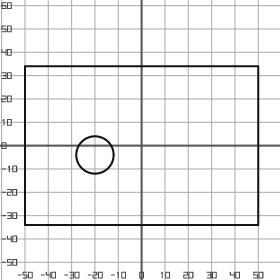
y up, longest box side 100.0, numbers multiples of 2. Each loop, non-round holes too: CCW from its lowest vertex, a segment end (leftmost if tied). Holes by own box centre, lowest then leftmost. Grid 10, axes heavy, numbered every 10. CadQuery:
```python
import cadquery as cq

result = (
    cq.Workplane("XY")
    .moveTo(-50.0, -34.0)
    .lineTo(50.0, -34.0)
    .lineTo(50.0, 34.0)
    .lineTo(-50.0, 34.0)
    .close()
    .moveTo(-20.0, -4.0)
    .circle(8.0)
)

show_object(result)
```